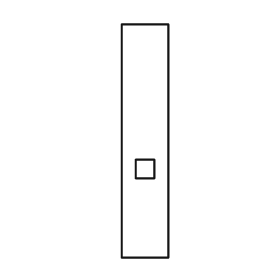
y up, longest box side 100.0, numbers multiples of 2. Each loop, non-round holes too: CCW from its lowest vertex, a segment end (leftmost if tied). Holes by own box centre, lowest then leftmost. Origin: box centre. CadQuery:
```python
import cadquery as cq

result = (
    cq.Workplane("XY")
    .moveTo(-10.0, -50.0)
    .lineTo(10.0, -50.0)
    .lineTo(10.0, 50.0)
    .lineTo(-10.0, 50.0)
    .close()
    .moveTo(-4.0, -16.0)
    .lineTo(4.0, -16.0)
    .lineTo(4.0, -8.0)
    .lineTo(-4.0, -8.0)
    .close()
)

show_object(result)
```